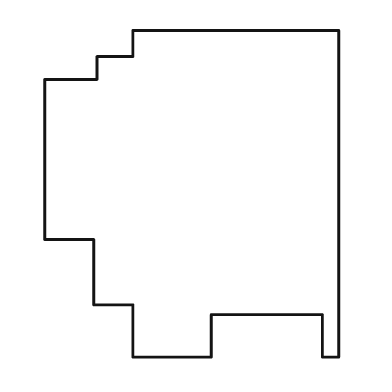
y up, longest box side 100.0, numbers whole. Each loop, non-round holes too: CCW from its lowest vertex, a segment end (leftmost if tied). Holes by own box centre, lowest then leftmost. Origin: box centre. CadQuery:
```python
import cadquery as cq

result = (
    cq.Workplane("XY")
    .moveTo(-18.0, -50.0)
    .lineTo(6.0, -50.0)
    .lineTo(6.0, -37.0)
    .lineTo(40.0, -37.0)
    .lineTo(40.0, -50.0)
    .lineTo(45.0, -50.0)
    .lineTo(45.0, 50.0)
    .lineTo(-18.0, 50.0)
    .lineTo(-18.0, 42.0)
    .lineTo(-29.0, 42.0)
    .lineTo(-29.0, 35.0)
    .lineTo(-45.0, 35.0)
    .lineTo(-45.0, -14.0)
    .lineTo(-30.0, -14.0)
    .lineTo(-30.0, -34.0)
    .lineTo(-18.0, -34.0)
    .close()
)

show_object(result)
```